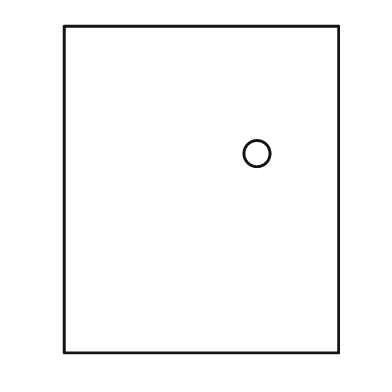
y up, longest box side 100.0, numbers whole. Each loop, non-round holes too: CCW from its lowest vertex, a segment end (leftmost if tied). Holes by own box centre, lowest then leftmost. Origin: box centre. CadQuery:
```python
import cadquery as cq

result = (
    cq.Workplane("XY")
    .moveTo(-42.0, -50.0)
    .lineTo(42.0, -50.0)
    .lineTo(42.0, 50.0)
    .lineTo(-42.0, 50.0)
    .close()
    .moveTo(17.0, 11.0)
    .circle(4.0)
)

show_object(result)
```